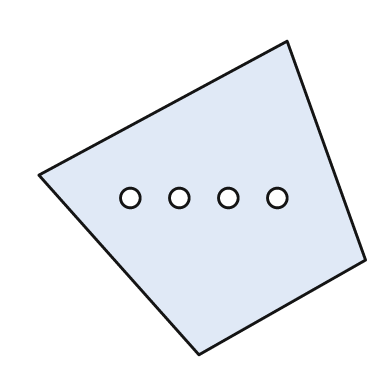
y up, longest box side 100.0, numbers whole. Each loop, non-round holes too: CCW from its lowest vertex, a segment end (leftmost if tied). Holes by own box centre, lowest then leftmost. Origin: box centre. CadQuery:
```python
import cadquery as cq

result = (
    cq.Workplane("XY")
    .moveTo(-1.0, -48.0)
    .lineTo(50.0, -19.0)
    .lineTo(26.0, 48.0)
    .lineTo(-50.0, 7.0)
    .close()
    .moveTo(-22.0, 0.0)
    .circle(3.0)
    .moveTo(-7.0, 0.0)
    .circle(3.0)
    .moveTo(8.0, 0.0)
    .circle(3.0)
    .moveTo(23.0, 0.0)
    .circle(3.0)
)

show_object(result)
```